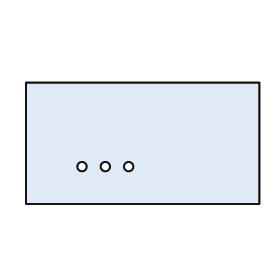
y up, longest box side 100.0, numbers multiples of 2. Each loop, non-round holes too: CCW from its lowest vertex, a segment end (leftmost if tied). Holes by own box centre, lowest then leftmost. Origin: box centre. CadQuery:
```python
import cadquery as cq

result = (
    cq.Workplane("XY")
    .moveTo(-50.0, -26.0)
    .lineTo(50.0, -26.0)
    .lineTo(50.0, 26.0)
    .lineTo(-50.0, 26.0)
    .close()
    .moveTo(-26.0, -10.0)
    .circle(2.0)
    .moveTo(-16.0, -10.0)
    .circle(2.0)
    .moveTo(-6.0, -10.0)
    .circle(2.0)
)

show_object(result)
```